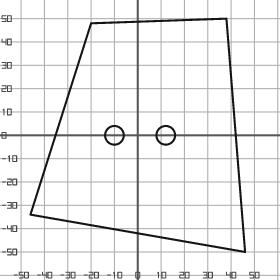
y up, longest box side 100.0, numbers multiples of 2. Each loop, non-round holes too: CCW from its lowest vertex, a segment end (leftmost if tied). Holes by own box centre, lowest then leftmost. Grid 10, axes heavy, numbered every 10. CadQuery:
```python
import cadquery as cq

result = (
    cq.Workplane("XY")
    .moveTo(46.0, -50.0)
    .lineTo(38.0, 50.0)
    .lineTo(-20.0, 48.0)
    .lineTo(-46.0, -34.0)
    .close()
    .moveTo(-10.0, 0.0)
    .circle(4.0)
    .moveTo(12.0, 0.0)
    .circle(4.0)
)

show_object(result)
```